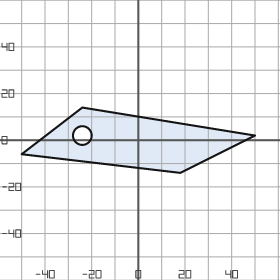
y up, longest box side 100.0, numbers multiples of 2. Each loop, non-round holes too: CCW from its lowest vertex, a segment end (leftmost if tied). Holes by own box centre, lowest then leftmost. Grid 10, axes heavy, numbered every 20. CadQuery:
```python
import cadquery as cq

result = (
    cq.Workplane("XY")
    .moveTo(18.0, -14.0)
    .lineTo(50.0, 2.0)
    .lineTo(-24.0, 14.0)
    .lineTo(-50.0, -6.0)
    .close()
    .moveTo(-24.0, 2.0)
    .circle(4.0)
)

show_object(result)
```